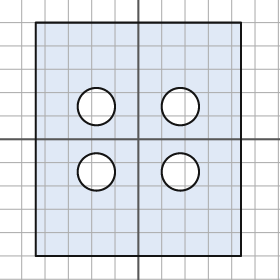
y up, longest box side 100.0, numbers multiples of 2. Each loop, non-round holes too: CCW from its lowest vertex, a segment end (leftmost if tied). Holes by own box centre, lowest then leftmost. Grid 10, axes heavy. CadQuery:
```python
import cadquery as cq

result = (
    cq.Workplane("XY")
    .moveTo(-44.0, -50.0)
    .lineTo(44.0, -50.0)
    .lineTo(44.0, 50.0)
    .lineTo(-44.0, 50.0)
    .close()
    .moveTo(-18.0, -14.0)
    .circle(8.0)
    .moveTo(18.0, -14.0)
    .circle(8.0)
    .moveTo(-18.0, 14.0)
    .circle(8.0)
    .moveTo(18.0, 14.0)
    .circle(8.0)
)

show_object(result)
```